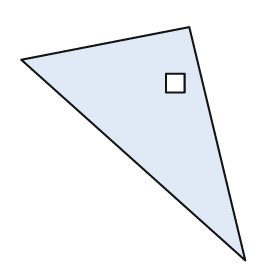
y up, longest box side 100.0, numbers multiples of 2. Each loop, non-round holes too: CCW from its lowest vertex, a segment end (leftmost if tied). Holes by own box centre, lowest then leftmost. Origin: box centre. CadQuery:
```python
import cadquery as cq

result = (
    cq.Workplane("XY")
    .moveTo(48.0, -50.0)
    .lineTo(24.0, 50.0)
    .lineTo(-48.0, 36.0)
    .close()
    .moveTo(14.0, 22.0)
    .lineTo(22.0, 22.0)
    .lineTo(22.0, 30.0)
    .lineTo(14.0, 30.0)
    .close()
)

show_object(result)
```